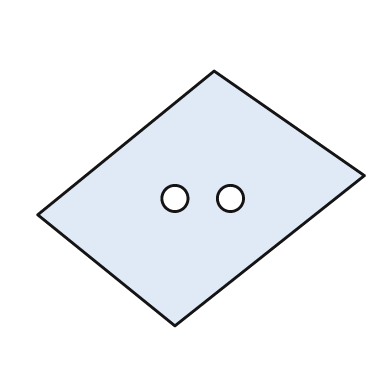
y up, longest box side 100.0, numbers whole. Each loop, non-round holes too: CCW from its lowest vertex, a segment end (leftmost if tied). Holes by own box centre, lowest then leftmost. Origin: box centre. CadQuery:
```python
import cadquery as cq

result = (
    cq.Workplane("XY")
    .moveTo(-8.0, -39.0)
    .lineTo(50.0, 7.0)
    .lineTo(4.0, 39.0)
    .lineTo(-50.0, -5.0)
    .close()
    .moveTo(-8.0, 0.0)
    .circle(4.0)
    .moveTo(9.0, 0.0)
    .circle(4.0)
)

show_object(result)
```